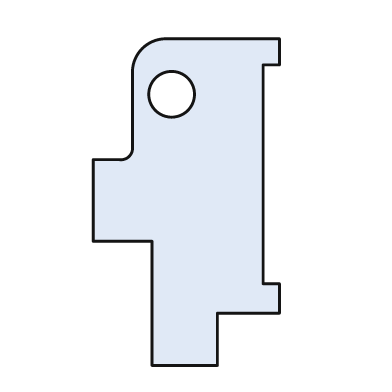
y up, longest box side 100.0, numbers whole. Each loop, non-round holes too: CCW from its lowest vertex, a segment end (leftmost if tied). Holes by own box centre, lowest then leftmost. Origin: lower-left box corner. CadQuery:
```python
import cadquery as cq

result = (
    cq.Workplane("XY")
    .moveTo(18.0, 0.0)
    .lineTo(38.0, 0.0)
    .lineTo(38.0, 16.0)
    .lineTo(57.0, 16.0)
    .lineTo(57.0, 25.0)
    .lineTo(52.0, 25.0)
    .lineTo(52.0, 92.0)
    .lineTo(57.0, 92.0)
    .lineTo(57.0, 100.0)
    .lineTo(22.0, 100.0)
    .threePointArc((15.0, 97.0), (12.0, 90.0))
    .lineTo(12.0, 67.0)
    .threePointArc((11.0, 64.0), (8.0, 63.0))
    .lineTo(0.0, 63.0)
    .lineTo(0.0, 38.0)
    .lineTo(18.0, 38.0)
    .close()
    .moveTo(24.0, 83.0)
    .circle(7.0)
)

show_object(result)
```